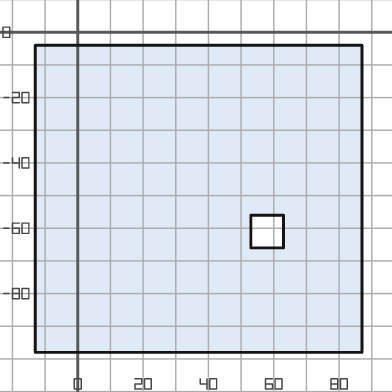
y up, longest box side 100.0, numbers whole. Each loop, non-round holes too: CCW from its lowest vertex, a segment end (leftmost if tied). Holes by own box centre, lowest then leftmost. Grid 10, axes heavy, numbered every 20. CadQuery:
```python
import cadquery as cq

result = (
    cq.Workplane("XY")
    .moveTo(-13.0, -98.0)
    .lineTo(87.0, -98.0)
    .lineTo(87.0, -4.0)
    .lineTo(-13.0, -4.0)
    .close()
    .moveTo(53.0, -66.0)
    .lineTo(63.0, -66.0)
    .lineTo(63.0, -56.0)
    .lineTo(53.0, -56.0)
    .close()
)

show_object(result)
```